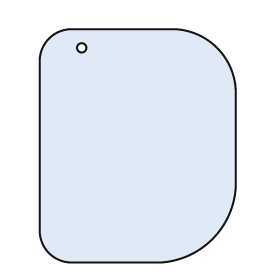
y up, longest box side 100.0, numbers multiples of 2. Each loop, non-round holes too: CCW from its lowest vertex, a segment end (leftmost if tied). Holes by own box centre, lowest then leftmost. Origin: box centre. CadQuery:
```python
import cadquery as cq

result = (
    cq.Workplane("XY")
    .moveTo(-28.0, -50.0)
    .lineTo(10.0, -50.0)
    .threePointArc((32.0, -40.0), (42.0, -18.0))
    .lineTo(42.0, 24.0)
    .threePointArc((34.0, 42.0), (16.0, 50.0))
    .lineTo(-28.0, 50.0)
    .threePointArc((-38.0, 46.0), (-42.0, 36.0))
    .lineTo(-42.0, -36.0)
    .threePointArc((-38.0, -46.0), (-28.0, -50.0))
    .close()
    .moveTo(-24.0, 42.0)
    .circle(2.0)
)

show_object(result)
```